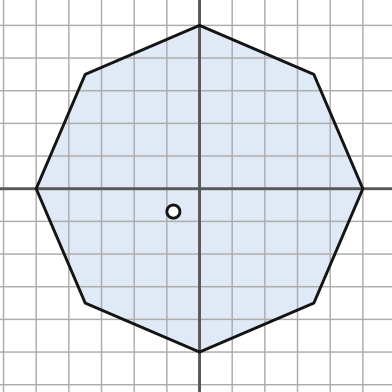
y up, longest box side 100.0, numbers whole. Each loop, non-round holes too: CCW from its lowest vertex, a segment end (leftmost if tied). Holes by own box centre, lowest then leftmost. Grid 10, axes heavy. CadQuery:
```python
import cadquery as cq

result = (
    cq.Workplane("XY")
    .moveTo(0.0, -50.0)
    .lineTo(35.0, -35.0)
    .lineTo(50.0, 0.0)
    .lineTo(35.0, 35.0)
    .lineTo(0.0, 50.0)
    .lineTo(-35.0, 35.0)
    .lineTo(-50.0, 0.0)
    .lineTo(-35.0, -35.0)
    .close()
    .moveTo(-8.0, -7.0)
    .circle(2.0)
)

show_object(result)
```